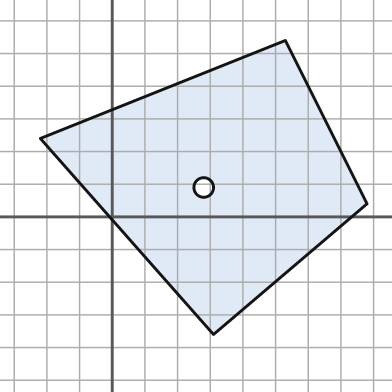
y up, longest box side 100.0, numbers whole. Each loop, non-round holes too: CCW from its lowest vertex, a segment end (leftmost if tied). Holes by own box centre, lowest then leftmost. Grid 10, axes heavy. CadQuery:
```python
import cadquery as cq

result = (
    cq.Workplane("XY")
    .moveTo(31.0, -36.0)
    .lineTo(78.0, 4.0)
    .lineTo(53.0, 54.0)
    .lineTo(-22.0, 24.0)
    .close()
    .moveTo(28.0, 9.0)
    .circle(3.0)
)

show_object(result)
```